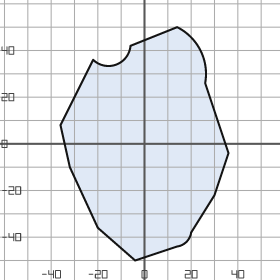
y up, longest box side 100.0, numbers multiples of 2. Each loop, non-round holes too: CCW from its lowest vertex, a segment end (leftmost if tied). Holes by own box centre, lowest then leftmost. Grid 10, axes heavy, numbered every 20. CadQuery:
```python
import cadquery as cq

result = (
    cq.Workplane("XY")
    .moveTo(-4.0, -50.0)
    .lineTo(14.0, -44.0)
    .threePointArc((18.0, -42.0), (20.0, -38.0))
    .lineTo(30.0, -22.0)
    .lineTo(36.0, -4.0)
    .lineTo(26.0, 26.0)
    .threePointArc((24.0, 40.0), (14.0, 50.0))
    .lineTo(-6.0, 42.0)
    .threePointArc((-12.0, 34.0), (-22.0, 36.0))
    .lineTo(-36.0, 8.0)
    .lineTo(-32.0, -10.0)
    .lineTo(-20.0, -36.0)
    .close()
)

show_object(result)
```